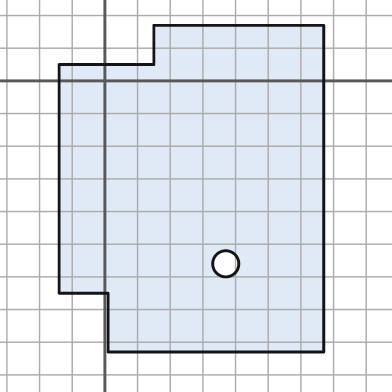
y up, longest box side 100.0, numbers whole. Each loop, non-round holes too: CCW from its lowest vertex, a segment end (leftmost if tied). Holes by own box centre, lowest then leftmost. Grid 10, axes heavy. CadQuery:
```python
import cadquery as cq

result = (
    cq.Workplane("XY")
    .moveTo(1.0, -83.0)
    .lineTo(67.0, -83.0)
    .lineTo(67.0, 17.0)
    .lineTo(15.0, 17.0)
    .lineTo(15.0, 5.0)
    .lineTo(-14.0, 5.0)
    .lineTo(-14.0, -65.0)
    .lineTo(1.0, -65.0)
    .close()
    .moveTo(37.0, -56.0)
    .circle(4.0)
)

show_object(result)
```